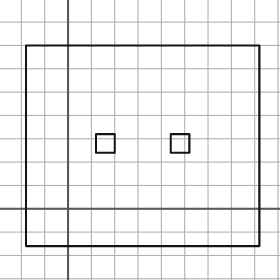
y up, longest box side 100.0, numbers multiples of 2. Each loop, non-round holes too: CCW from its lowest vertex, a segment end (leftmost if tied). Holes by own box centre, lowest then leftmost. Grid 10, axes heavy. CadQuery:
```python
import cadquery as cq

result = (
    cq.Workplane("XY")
    .moveTo(-18.0, -16.0)
    .lineTo(82.0, -16.0)
    .lineTo(82.0, 70.0)
    .lineTo(-18.0, 70.0)
    .close()
    .moveTo(12.0, 24.0)
    .lineTo(20.0, 24.0)
    .lineTo(20.0, 32.0)
    .lineTo(12.0, 32.0)
    .close()
    .moveTo(44.0, 24.0)
    .lineTo(52.0, 24.0)
    .lineTo(52.0, 32.0)
    .lineTo(44.0, 32.0)
    .close()
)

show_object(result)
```